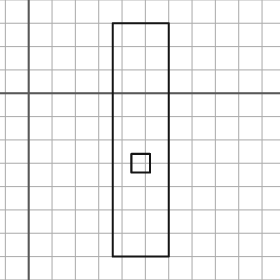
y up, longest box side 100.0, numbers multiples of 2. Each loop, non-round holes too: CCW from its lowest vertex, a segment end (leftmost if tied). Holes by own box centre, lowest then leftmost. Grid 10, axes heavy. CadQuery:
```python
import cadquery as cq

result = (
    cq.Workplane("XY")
    .moveTo(36.0, -70.0)
    .lineTo(60.0, -70.0)
    .lineTo(60.0, 30.0)
    .lineTo(36.0, 30.0)
    .close()
    .moveTo(44.0, -34.0)
    .lineTo(52.0, -34.0)
    .lineTo(52.0, -26.0)
    .lineTo(44.0, -26.0)
    .close()
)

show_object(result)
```